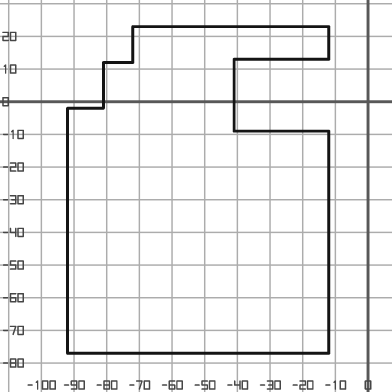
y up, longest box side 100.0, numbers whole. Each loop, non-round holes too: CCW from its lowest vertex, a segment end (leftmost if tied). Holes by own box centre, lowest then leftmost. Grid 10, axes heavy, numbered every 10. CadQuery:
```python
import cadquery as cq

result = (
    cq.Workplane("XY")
    .moveTo(-92.0, -77.0)
    .lineTo(-12.0, -77.0)
    .lineTo(-12.0, -9.0)
    .lineTo(-41.0, -9.0)
    .lineTo(-41.0, 13.0)
    .lineTo(-12.0, 13.0)
    .lineTo(-12.0, 23.0)
    .lineTo(-72.0, 23.0)
    .lineTo(-72.0, 12.0)
    .lineTo(-81.0, 12.0)
    .lineTo(-81.0, -2.0)
    .lineTo(-92.0, -2.0)
    .close()
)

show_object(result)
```